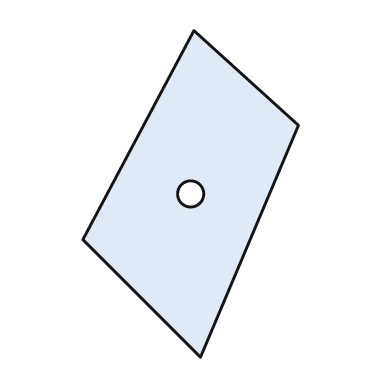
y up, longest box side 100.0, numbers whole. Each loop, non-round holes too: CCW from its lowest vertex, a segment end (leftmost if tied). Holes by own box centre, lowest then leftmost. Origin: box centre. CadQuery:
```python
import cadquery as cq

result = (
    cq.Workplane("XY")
    .moveTo(3.0, -50.0)
    .lineTo(33.0, 21.0)
    .lineTo(1.0, 50.0)
    .lineTo(-33.0, -14.0)
    .close()
    .moveTo(0.0, 0.0)
    .circle(4.0)
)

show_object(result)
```